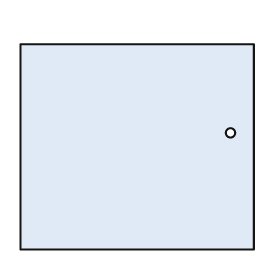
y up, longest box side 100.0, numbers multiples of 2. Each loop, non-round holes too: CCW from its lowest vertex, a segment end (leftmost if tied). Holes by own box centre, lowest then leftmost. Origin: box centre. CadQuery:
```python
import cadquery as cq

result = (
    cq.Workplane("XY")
    .moveTo(-50.0, -44.0)
    .lineTo(50.0, -44.0)
    .lineTo(50.0, 44.0)
    .lineTo(-50.0, 44.0)
    .close()
    .moveTo(40.0, 6.0)
    .circle(2.0)
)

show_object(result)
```